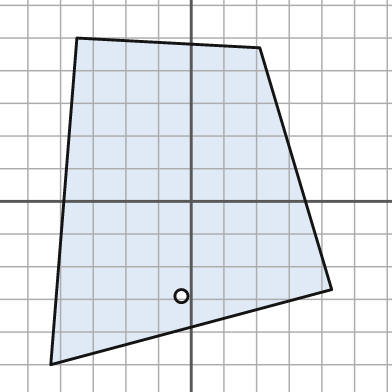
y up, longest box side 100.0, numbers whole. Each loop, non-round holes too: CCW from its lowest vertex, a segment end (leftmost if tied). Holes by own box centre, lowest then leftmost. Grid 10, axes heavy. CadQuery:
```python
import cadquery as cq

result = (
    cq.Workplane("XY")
    .moveTo(-43.0, -50.0)
    .lineTo(43.0, -27.0)
    .lineTo(21.0, 47.0)
    .lineTo(-35.0, 50.0)
    .close()
    .moveTo(-3.0, -29.0)
    .circle(2.0)
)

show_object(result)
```